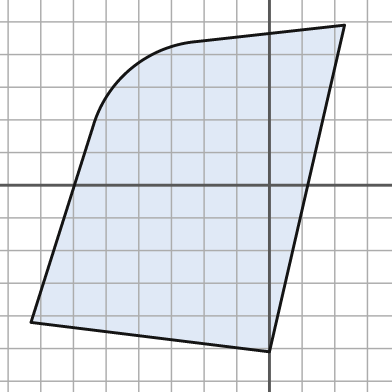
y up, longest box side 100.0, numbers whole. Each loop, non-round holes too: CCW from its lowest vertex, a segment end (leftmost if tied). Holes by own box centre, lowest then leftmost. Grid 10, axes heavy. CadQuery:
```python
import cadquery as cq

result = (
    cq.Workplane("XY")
    .moveTo(0.0, -51.0)
    .lineTo(23.0, 49.0)
    .lineTo(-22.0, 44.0)
    .threePointArc((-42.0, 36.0), (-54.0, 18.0))
    .lineTo(-73.0, -42.0)
    .close()
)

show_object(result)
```